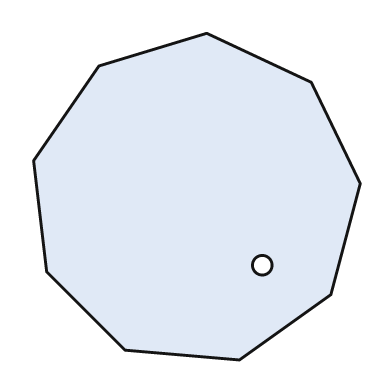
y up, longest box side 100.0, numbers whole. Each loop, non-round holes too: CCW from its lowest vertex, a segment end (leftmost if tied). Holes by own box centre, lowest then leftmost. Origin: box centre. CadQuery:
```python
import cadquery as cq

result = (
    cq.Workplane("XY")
    .moveTo(13.0, -50.0)
    .lineTo(41.0, -30.0)
    .lineTo(50.0, 4.0)
    .lineTo(35.0, 35.0)
    .lineTo(3.0, 50.0)
    .lineTo(-30.0, 40.0)
    .lineTo(-50.0, 11.0)
    .lineTo(-46.0, -23.0)
    .lineTo(-22.0, -47.0)
    .close()
    .moveTo(20.0, -21.0)
    .circle(3.0)
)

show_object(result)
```